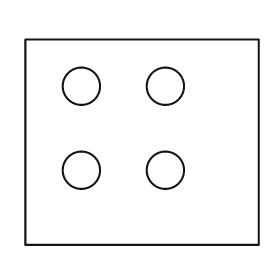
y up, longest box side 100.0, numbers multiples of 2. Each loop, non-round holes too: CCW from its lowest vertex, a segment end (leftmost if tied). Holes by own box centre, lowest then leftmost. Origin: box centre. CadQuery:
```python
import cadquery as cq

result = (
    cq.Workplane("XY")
    .moveTo(-50.0, -44.0)
    .lineTo(50.0, -44.0)
    .lineTo(50.0, 44.0)
    .lineTo(-50.0, 44.0)
    .close()
    .moveTo(-26.0, -12.0)
    .circle(8.0)
    .moveTo(10.0, -12.0)
    .circle(8.0)
    .moveTo(-26.0, 24.0)
    .circle(8.0)
    .moveTo(10.0, 24.0)
    .circle(8.0)
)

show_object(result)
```